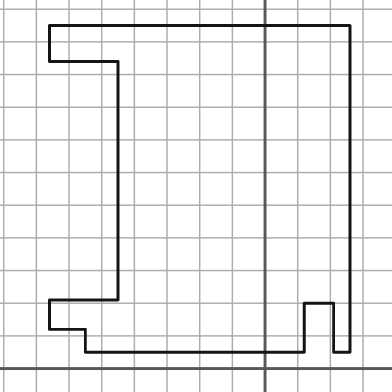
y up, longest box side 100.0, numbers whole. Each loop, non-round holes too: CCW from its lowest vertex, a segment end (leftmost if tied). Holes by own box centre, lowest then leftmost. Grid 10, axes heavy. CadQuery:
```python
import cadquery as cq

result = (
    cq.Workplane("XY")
    .moveTo(-55.0, 5.0)
    .lineTo(12.0, 5.0)
    .lineTo(12.0, 20.0)
    .lineTo(21.0, 20.0)
    .lineTo(21.0, 5.0)
    .lineTo(26.0, 5.0)
    .lineTo(26.0, 105.0)
    .lineTo(-66.0, 105.0)
    .lineTo(-66.0, 94.0)
    .lineTo(-45.0, 94.0)
    .lineTo(-45.0, 21.0)
    .lineTo(-66.0, 21.0)
    .lineTo(-66.0, 12.0)
    .lineTo(-55.0, 12.0)
    .close()
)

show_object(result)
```